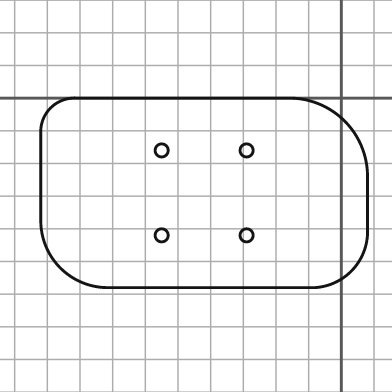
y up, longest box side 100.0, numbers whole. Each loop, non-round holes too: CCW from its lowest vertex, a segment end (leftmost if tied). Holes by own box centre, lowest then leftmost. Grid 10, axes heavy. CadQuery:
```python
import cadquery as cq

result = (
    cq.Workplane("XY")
    .moveTo(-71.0, -58.0)
    .lineTo(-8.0, -58.0)
    .threePointArc((3.0, -53.0), (8.0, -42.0))
    .lineTo(8.0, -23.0)
    .threePointArc((1.0, -7.0), (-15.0, 0.0))
    .lineTo(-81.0, 0.0)
    .threePointArc((-89.0, -3.0), (-92.0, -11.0))
    .lineTo(-92.0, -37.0)
    .threePointArc((-86.0, -52.0), (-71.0, -58.0))
    .close()
    .moveTo(-55.0, -42.0)
    .circle(2.0)
    .moveTo(-29.0, -42.0)
    .circle(2.0)
    .moveTo(-55.0, -16.0)
    .circle(2.0)
    .moveTo(-29.0, -16.0)
    .circle(2.0)
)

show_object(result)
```